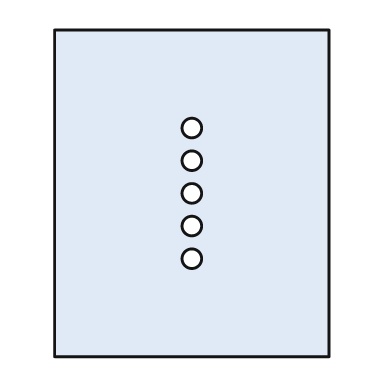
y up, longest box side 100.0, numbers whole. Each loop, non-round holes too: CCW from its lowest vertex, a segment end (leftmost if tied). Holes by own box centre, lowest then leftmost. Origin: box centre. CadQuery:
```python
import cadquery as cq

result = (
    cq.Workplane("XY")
    .moveTo(-42.0, -50.0)
    .lineTo(42.0, -50.0)
    .lineTo(42.0, 50.0)
    .lineTo(-42.0, 50.0)
    .close()
    .moveTo(0.0, -20.0)
    .circle(3.0)
    .moveTo(0.0, -10.0)
    .circle(3.0)
    .moveTo(0.0, 0.0)
    .circle(3.0)
    .moveTo(0.0, 10.0)
    .circle(3.0)
    .moveTo(0.0, 20.0)
    .circle(3.0)
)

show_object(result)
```